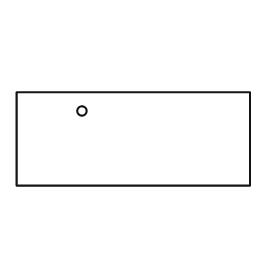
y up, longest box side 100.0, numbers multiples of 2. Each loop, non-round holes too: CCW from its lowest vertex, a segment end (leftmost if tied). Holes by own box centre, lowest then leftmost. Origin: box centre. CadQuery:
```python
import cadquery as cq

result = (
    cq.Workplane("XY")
    .moveTo(-50.0, -20.0)
    .lineTo(50.0, -20.0)
    .lineTo(50.0, 20.0)
    .lineTo(-50.0, 20.0)
    .close()
    .moveTo(-22.0, 12.0)
    .circle(2.0)
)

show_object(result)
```